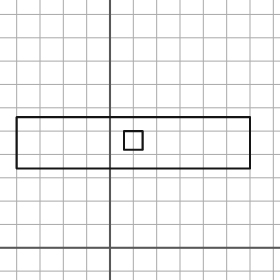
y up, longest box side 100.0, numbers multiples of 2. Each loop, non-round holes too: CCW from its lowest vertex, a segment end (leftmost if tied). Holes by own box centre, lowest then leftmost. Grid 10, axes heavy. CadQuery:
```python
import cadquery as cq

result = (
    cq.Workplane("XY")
    .moveTo(-40.0, 34.0)
    .lineTo(60.0, 34.0)
    .lineTo(60.0, 56.0)
    .lineTo(-40.0, 56.0)
    .close()
    .moveTo(6.0, 42.0)
    .lineTo(14.0, 42.0)
    .lineTo(14.0, 50.0)
    .lineTo(6.0, 50.0)
    .close()
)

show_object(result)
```